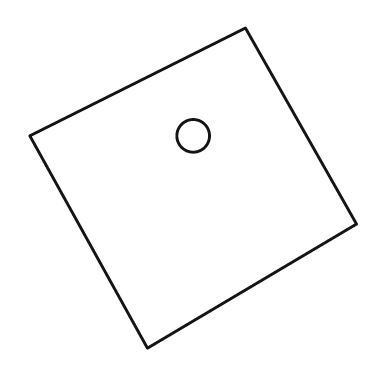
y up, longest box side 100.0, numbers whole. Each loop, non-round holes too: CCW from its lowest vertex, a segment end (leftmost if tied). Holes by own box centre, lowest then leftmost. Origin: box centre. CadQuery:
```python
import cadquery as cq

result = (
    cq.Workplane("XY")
    .moveTo(-14.0, -49.0)
    .lineTo(50.0, -11.0)
    .lineTo(16.0, 49.0)
    .lineTo(-50.0, 16.0)
    .close()
    .moveTo(0.0, 16.0)
    .circle(5.0)
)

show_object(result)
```